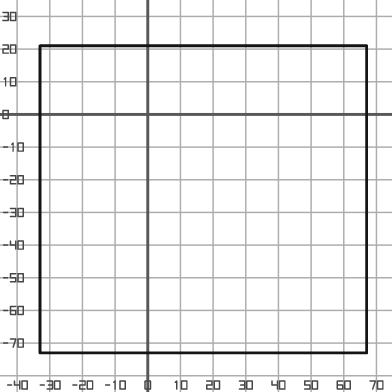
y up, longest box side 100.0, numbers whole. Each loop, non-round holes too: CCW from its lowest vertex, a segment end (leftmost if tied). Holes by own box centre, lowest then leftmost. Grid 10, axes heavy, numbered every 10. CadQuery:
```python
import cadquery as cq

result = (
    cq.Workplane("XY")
    .moveTo(-33.0, -73.0)
    .lineTo(67.0, -73.0)
    .lineTo(67.0, 21.0)
    .lineTo(-33.0, 21.0)
    .close()
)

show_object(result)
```